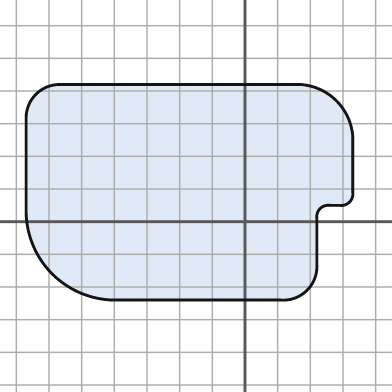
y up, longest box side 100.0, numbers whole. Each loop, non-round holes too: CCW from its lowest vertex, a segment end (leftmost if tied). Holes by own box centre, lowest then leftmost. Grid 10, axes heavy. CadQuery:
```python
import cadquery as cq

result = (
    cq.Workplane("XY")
    .moveTo(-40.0, -24.0)
    .lineTo(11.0, -24.0)
    .threePointArc((19.0, -21.0), (22.0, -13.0))
    .lineTo(22.0, 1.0)
    .threePointArc((23.0, 4.0), (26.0, 5.0))
    .lineTo(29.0, 5.0)
    .threePointArc((32.0, 6.0), (33.0, 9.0))
    .lineTo(33.0, 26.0)
    .threePointArc((28.0, 37.0), (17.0, 42.0))
    .lineTo(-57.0, 42.0)
    .threePointArc((-64.0, 39.0), (-67.0, 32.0))
    .lineTo(-67.0, 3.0)
    .threePointArc((-59.0, -16.0), (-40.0, -24.0))
    .close()
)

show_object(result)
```